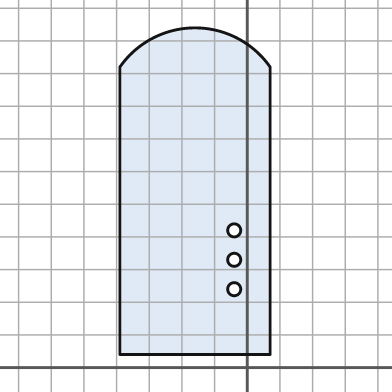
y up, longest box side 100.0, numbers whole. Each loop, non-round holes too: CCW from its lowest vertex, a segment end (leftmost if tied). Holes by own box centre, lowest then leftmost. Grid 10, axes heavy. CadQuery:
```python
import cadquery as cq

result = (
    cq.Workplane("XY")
    .moveTo(-39.0, 4.0)
    .lineTo(7.0, 4.0)
    .lineTo(7.0, 92.0)
    .threePointArc((-16.0, 104.0), (-39.0, 92.0))
    .close()
    .moveTo(-4.0, 24.0)
    .circle(2.0)
    .moveTo(-4.0, 33.0)
    .circle(2.0)
    .moveTo(-4.0, 42.0)
    .circle(2.0)
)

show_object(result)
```